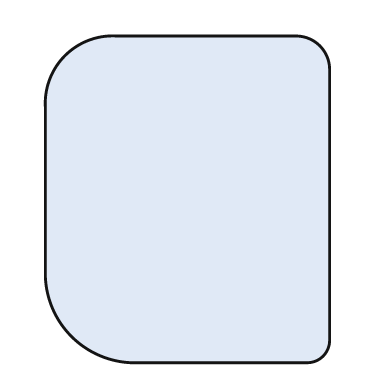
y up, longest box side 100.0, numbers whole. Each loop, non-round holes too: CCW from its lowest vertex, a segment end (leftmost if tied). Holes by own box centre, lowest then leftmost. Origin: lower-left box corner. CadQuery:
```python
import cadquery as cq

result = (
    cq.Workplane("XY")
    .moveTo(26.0, 0.0)
    .lineTo(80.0, 0.0)
    .threePointArc((85.0, 2.0), (87.0, 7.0))
    .lineTo(87.0, 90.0)
    .threePointArc((84.0, 97.0), (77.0, 100.0))
    .lineTo(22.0, 100.0)
    .threePointArc((6.0, 94.0), (0.0, 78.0))
    .lineTo(0.0, 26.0)
    .threePointArc((8.0, 8.0), (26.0, 0.0))
    .close()
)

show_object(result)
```